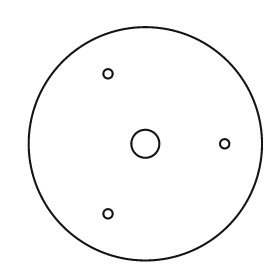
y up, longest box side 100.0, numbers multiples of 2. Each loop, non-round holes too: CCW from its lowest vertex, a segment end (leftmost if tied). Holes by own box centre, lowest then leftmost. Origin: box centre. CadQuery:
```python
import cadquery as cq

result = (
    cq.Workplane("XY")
    .moveTo(0.0, 0.0)
    .circle(50.0)
    .moveTo(-16.0, -30.0)
    .circle(2.0)
    .moveTo(0.0, 0.0)
    .circle(6.0)
    .moveTo(34.0, 0.0)
    .circle(2.0)
    .moveTo(-16.0, 30.0)
    .circle(2.0)
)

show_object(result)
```